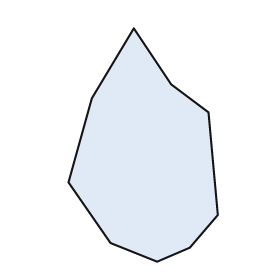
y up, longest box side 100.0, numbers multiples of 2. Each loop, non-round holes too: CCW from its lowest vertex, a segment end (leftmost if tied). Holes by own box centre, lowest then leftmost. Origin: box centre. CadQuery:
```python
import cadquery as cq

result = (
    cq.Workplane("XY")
    .moveTo(6.0, -50.0)
    .lineTo(20.0, -44.0)
    .lineTo(32.0, -30.0)
    .lineTo(28.0, 14.0)
    .lineTo(12.0, 26.0)
    .lineTo(-4.0, 50.0)
    .lineTo(-22.0, 20.0)
    .lineTo(-32.0, -16.0)
    .lineTo(-14.0, -42.0)
    .close()
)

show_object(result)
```